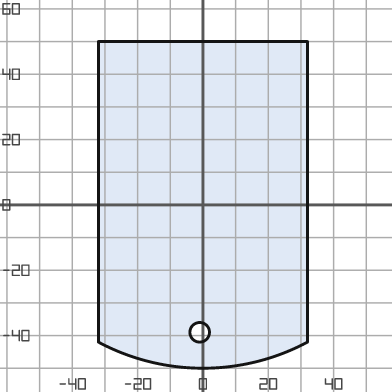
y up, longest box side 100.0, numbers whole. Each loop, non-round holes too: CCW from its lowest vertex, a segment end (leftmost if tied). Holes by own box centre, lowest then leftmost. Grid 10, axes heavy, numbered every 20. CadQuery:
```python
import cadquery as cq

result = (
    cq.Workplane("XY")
    .moveTo(-32.0, -42.0)
    .threePointArc((0.0, -50.0), (32.0, -42.0))
    .lineTo(32.0, 50.0)
    .lineTo(-32.0, 50.0)
    .close()
    .moveTo(-1.0, -39.0)
    .circle(3.0)
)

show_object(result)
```